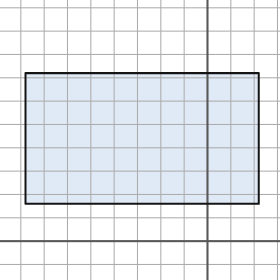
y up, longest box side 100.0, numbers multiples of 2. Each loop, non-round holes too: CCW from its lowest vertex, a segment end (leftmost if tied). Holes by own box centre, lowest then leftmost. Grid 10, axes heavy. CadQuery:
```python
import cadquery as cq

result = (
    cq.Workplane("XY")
    .moveTo(-78.0, 16.0)
    .lineTo(22.0, 16.0)
    .lineTo(22.0, 72.0)
    .lineTo(-78.0, 72.0)
    .close()
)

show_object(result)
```